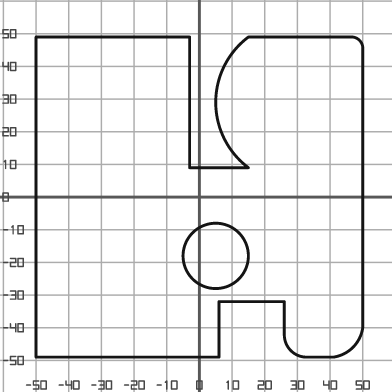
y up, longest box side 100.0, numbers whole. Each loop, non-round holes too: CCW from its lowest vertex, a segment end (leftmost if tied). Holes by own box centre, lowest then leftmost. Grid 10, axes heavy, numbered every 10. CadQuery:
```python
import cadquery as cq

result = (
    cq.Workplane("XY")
    .moveTo(-50.0, -49.0)
    .lineTo(6.0, -49.0)
    .lineTo(6.0, -32.0)
    .lineTo(26.0, -32.0)
    .lineTo(26.0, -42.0)
    .threePointArc((28.0, -47.0), (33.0, -49.0))
    .lineTo(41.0, -49.0)
    .threePointArc((47.0, -46.0), (50.0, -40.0))
    .lineTo(50.0, 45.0)
    .threePointArc((49.0, 48.0), (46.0, 49.0))
    .lineTo(15.0, 49.0)
    .threePointArc((5.0, 29.0), (15.0, 9.0))
    .lineTo(-3.0, 9.0)
    .lineTo(-3.0, 49.0)
    .lineTo(-50.0, 49.0)
    .close()
    .moveTo(5.0, -18.0)
    .circle(10.0)
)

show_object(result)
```